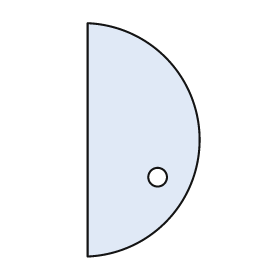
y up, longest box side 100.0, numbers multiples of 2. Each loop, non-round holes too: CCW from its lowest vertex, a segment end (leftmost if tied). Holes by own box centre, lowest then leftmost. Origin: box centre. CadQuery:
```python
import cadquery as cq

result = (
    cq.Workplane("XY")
    .moveTo(-24.0, -50.0)
    .threePointArc((24.0, 0.0), (-24.0, 50.0))
    .close()
    .moveTo(6.0, -16.0)
    .circle(4.0)
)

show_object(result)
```